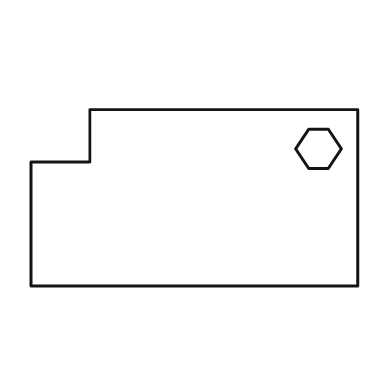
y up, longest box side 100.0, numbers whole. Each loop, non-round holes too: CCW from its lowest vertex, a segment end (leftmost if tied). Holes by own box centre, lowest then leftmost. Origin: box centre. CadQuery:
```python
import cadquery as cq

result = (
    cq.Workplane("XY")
    .moveTo(-50.0, -27.0)
    .lineTo(50.0, -27.0)
    .lineTo(50.0, 27.0)
    .lineTo(-32.0, 27.0)
    .lineTo(-32.0, 11.0)
    .lineTo(-50.0, 11.0)
    .close()
    .moveTo(35.0, 9.0)
    .lineTo(41.0, 9.0)
    .lineTo(45.0, 15.0)
    .lineTo(41.0, 21.0)
    .lineTo(35.0, 21.0)
    .lineTo(31.0, 15.0)
    .close()
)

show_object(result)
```